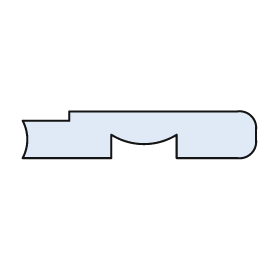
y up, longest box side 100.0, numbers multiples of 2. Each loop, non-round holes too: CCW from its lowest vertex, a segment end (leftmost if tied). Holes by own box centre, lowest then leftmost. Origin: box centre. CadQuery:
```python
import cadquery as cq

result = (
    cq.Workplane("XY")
    .moveTo(-50.0, -10.0)
    .lineTo(-12.0, -10.0)
    .lineTo(-12.0, 0.0)
    .threePointArc((2.0, -4.0), (16.0, 0.0))
    .lineTo(16.0, -10.0)
    .lineTo(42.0, -10.0)
    .threePointArc((48.0, -8.0), (50.0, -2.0))
    .lineTo(50.0, 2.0)
    .threePointArc((48.0, 8.0), (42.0, 10.0))
    .lineTo(-30.0, 10.0)
    .lineTo(-30.0, 6.0)
    .lineTo(-50.0, 6.0)
    .threePointArc((-48.0, -2.0), (-50.0, -10.0))
    .close()
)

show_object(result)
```